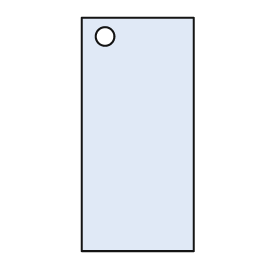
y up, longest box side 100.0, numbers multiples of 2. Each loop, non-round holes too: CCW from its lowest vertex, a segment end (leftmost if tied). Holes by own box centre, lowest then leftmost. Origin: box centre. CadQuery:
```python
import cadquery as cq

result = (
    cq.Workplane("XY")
    .moveTo(-24.0, -50.0)
    .lineTo(24.0, -50.0)
    .lineTo(24.0, 50.0)
    .lineTo(-24.0, 50.0)
    .close()
    .moveTo(-14.0, 42.0)
    .circle(4.0)
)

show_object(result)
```